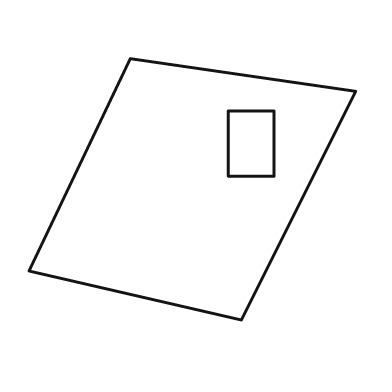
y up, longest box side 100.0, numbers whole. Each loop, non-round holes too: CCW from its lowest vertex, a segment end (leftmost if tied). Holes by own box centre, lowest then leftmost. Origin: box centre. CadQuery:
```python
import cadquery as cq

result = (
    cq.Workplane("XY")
    .moveTo(15.0, -40.0)
    .lineTo(50.0, 30.0)
    .lineTo(-19.0, 40.0)
    .lineTo(-50.0, -25.0)
    .close()
    .moveTo(11.0, 4.0)
    .lineTo(25.0, 4.0)
    .lineTo(25.0, 24.0)
    .lineTo(11.0, 24.0)
    .close()
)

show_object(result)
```